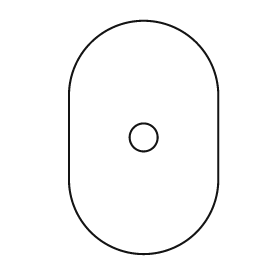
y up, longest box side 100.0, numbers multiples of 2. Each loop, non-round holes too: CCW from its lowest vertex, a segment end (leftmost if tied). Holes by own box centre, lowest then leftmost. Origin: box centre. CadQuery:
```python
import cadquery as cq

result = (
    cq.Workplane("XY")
    .moveTo(-32.0, -18.0)
    .threePointArc((0.0, -50.0), (32.0, -18.0))
    .lineTo(32.0, 18.0)
    .threePointArc((0.0, 50.0), (-32.0, 18.0))
    .close()
    .moveTo(0.0, 0.0)
    .circle(6.0)
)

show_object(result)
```